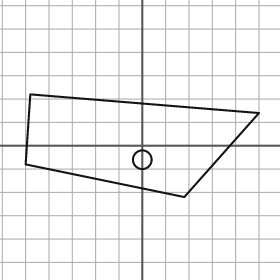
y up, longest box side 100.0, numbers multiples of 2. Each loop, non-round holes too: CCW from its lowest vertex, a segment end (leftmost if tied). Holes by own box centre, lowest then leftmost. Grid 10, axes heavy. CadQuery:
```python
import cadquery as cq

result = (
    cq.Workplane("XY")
    .moveTo(18.0, -22.0)
    .lineTo(50.0, 14.0)
    .lineTo(-48.0, 22.0)
    .lineTo(-50.0, -8.0)
    .close()
    .moveTo(0.0, -6.0)
    .circle(4.0)
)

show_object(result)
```